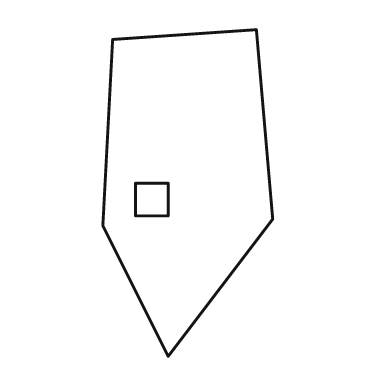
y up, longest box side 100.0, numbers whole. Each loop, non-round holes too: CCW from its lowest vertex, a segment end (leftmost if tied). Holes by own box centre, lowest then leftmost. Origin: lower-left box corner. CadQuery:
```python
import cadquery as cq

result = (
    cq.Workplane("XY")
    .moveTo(20.0, 0.0)
    .lineTo(52.0, 42.0)
    .lineTo(47.0, 100.0)
    .lineTo(3.0, 97.0)
    .lineTo(0.0, 40.0)
    .close()
    .moveTo(10.0, 43.0)
    .lineTo(20.0, 43.0)
    .lineTo(20.0, 53.0)
    .lineTo(10.0, 53.0)
    .close()
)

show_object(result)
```